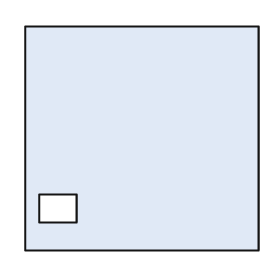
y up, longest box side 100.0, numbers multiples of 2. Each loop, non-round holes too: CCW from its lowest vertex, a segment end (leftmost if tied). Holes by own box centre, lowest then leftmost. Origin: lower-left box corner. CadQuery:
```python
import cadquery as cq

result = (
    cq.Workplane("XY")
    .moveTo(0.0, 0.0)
    .lineTo(100.0, 0.0)
    .lineTo(100.0, 96.0)
    .lineTo(0.0, 96.0)
    .close()
    .moveTo(6.0, 12.0)
    .lineTo(22.0, 12.0)
    .lineTo(22.0, 24.0)
    .lineTo(6.0, 24.0)
    .close()
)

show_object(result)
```